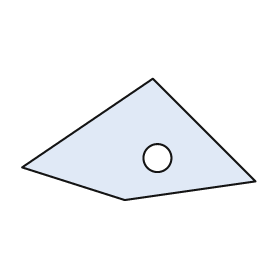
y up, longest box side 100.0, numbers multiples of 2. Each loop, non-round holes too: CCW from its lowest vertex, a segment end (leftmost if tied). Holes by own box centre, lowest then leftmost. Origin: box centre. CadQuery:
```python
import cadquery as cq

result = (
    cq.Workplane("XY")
    .moveTo(-6.0, -26.0)
    .lineTo(50.0, -18.0)
    .lineTo(6.0, 26.0)
    .lineTo(-50.0, -12.0)
    .close()
    .moveTo(8.0, -8.0)
    .circle(6.0)
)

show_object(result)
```